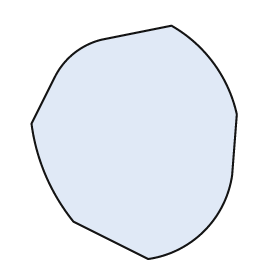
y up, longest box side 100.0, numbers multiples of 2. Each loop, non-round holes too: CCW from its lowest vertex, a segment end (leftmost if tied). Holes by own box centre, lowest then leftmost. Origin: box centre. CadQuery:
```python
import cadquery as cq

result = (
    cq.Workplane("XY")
    .moveTo(6.0, -50.0)
    .threePointArc((30.0, -38.0), (42.0, -14.0))
    .lineTo(44.0, 12.0)
    .threePointArc((34.0, 34.0), (16.0, 50.0))
    .lineTo(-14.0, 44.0)
    .threePointArc((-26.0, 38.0), (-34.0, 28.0))
    .lineTo(-44.0, 8.0)
    .threePointArc((-38.0, -14.0), (-26.0, -34.0))
    .close()
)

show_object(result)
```